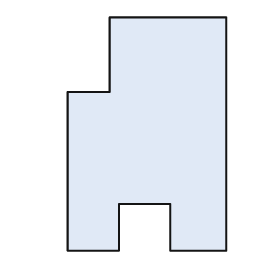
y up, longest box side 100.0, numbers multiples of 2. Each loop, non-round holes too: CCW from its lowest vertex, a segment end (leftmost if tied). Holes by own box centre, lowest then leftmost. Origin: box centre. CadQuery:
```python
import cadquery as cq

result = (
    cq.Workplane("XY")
    .moveTo(-34.0, -50.0)
    .lineTo(-12.0, -50.0)
    .lineTo(-12.0, -30.0)
    .lineTo(10.0, -30.0)
    .lineTo(10.0, -50.0)
    .lineTo(34.0, -50.0)
    .lineTo(34.0, 50.0)
    .lineTo(-16.0, 50.0)
    .lineTo(-16.0, 18.0)
    .lineTo(-34.0, 18.0)
    .close()
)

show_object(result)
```